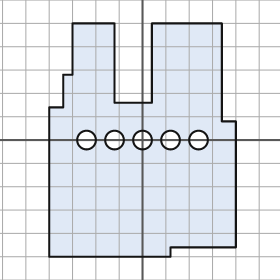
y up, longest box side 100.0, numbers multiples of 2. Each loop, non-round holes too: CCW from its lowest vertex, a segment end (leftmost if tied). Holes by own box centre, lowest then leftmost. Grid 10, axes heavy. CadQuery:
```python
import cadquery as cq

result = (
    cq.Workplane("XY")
    .moveTo(-40.0, -50.0)
    .lineTo(12.0, -50.0)
    .lineTo(12.0, -46.0)
    .lineTo(40.0, -46.0)
    .lineTo(40.0, 8.0)
    .lineTo(34.0, 8.0)
    .lineTo(34.0, 50.0)
    .lineTo(4.0, 50.0)
    .lineTo(4.0, 16.0)
    .lineTo(-12.0, 16.0)
    .lineTo(-12.0, 50.0)
    .lineTo(-30.0, 50.0)
    .lineTo(-30.0, 28.0)
    .lineTo(-34.0, 28.0)
    .lineTo(-34.0, 14.0)
    .lineTo(-40.0, 14.0)
    .close()
    .moveTo(-24.0, 0.0)
    .circle(4.0)
    .moveTo(-12.0, 0.0)
    .circle(4.0)
    .moveTo(0.0, 0.0)
    .circle(4.0)
    .moveTo(12.0, 0.0)
    .circle(4.0)
    .moveTo(24.0, 0.0)
    .circle(4.0)
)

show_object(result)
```